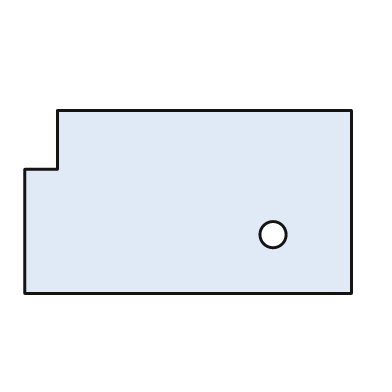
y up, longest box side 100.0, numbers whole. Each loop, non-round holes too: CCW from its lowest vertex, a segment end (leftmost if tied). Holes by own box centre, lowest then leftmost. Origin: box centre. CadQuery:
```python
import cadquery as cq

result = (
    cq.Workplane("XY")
    .moveTo(-50.0, -28.0)
    .lineTo(50.0, -28.0)
    .lineTo(50.0, 28.0)
    .lineTo(-40.0, 28.0)
    .lineTo(-40.0, 10.0)
    .lineTo(-50.0, 10.0)
    .close()
    .moveTo(26.0, -10.0)
    .circle(4.0)
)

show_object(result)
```